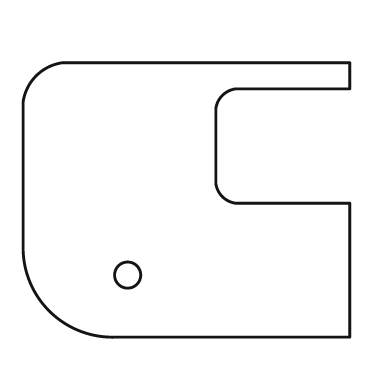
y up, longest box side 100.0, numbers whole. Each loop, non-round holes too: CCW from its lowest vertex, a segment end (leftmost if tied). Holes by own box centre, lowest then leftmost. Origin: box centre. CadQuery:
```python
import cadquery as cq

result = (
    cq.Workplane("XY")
    .moveTo(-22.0, -42.0)
    .lineTo(50.0, -42.0)
    .lineTo(50.0, -1.0)
    .lineTo(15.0, -1.0)
    .threePointArc((11.0, 1.0), (9.0, 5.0))
    .lineTo(9.0, 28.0)
    .threePointArc((11.0, 32.0), (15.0, 34.0))
    .lineTo(50.0, 34.0)
    .lineTo(50.0, 42.0)
    .lineTo(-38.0, 42.0)
    .threePointArc((-46.0, 38.0), (-50.0, 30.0))
    .lineTo(-50.0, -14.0)
    .threePointArc((-42.0, -34.0), (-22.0, -42.0))
    .close()
    .moveTo(-18.0, -23.0)
    .circle(4.0)
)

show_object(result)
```